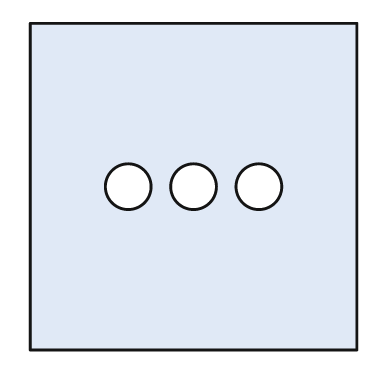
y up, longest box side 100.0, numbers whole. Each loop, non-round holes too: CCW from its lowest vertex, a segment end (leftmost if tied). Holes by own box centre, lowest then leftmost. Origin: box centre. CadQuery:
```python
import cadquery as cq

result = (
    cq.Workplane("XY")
    .moveTo(-50.0, -50.0)
    .lineTo(50.0, -50.0)
    .lineTo(50.0, 50.0)
    .lineTo(-50.0, 50.0)
    .close()
    .moveTo(-20.0, 0.0)
    .circle(7.0)
    .moveTo(0.0, 0.0)
    .circle(7.0)
    .moveTo(20.0, 0.0)
    .circle(7.0)
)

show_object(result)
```